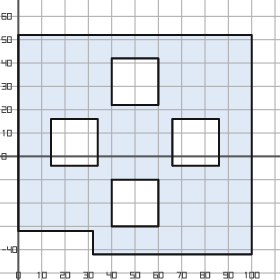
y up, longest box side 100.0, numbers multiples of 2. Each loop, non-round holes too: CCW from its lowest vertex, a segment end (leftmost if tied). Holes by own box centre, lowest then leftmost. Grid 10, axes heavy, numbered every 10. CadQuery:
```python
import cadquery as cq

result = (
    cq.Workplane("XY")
    .moveTo(32.0, -42.0)
    .lineTo(100.0, -42.0)
    .lineTo(100.0, 52.0)
    .lineTo(0.0, 52.0)
    .lineTo(0.0, -32.0)
    .lineTo(32.0, -32.0)
    .close()
    .moveTo(40.0, -30.0)
    .lineTo(60.0, -30.0)
    .lineTo(60.0, -10.0)
    .lineTo(40.0, -10.0)
    .close()
    .moveTo(14.0, -4.0)
    .lineTo(34.0, -4.0)
    .lineTo(34.0, 16.0)
    .lineTo(14.0, 16.0)
    .close()
    .moveTo(66.0, -4.0)
    .lineTo(86.0, -4.0)
    .lineTo(86.0, 16.0)
    .lineTo(66.0, 16.0)
    .close()
    .moveTo(40.0, 22.0)
    .lineTo(60.0, 22.0)
    .lineTo(60.0, 42.0)
    .lineTo(40.0, 42.0)
    .close()
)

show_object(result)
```